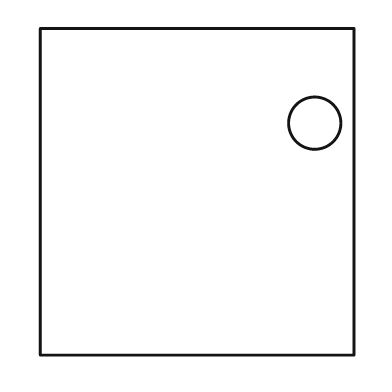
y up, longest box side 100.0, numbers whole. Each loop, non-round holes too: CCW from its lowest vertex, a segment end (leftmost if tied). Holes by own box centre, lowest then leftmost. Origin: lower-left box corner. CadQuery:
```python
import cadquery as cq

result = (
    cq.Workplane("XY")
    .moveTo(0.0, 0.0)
    .lineTo(96.0, 0.0)
    .lineTo(96.0, 100.0)
    .lineTo(0.0, 100.0)
    .close()
    .moveTo(84.0, 71.0)
    .circle(8.0)
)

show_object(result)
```